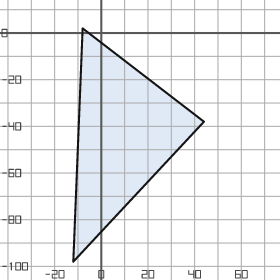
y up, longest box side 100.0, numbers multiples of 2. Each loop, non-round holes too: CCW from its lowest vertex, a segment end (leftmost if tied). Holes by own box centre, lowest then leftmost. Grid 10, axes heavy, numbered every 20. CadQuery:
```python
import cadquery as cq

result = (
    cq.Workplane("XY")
    .moveTo(-12.0, -98.0)
    .lineTo(44.0, -38.0)
    .lineTo(-8.0, 2.0)
    .close()
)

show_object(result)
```